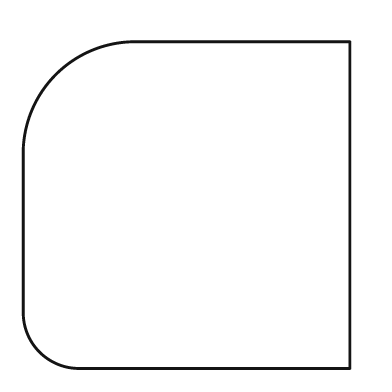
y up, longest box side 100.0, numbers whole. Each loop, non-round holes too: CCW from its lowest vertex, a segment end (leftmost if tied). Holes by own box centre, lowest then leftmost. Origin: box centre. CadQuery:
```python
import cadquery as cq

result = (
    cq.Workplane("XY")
    .moveTo(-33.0, -50.0)
    .lineTo(50.0, -50.0)
    .lineTo(50.0, 50.0)
    .lineTo(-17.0, 50.0)
    .threePointArc((-40.0, 40.0), (-50.0, 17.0))
    .lineTo(-50.0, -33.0)
    .threePointArc((-45.0, -45.0), (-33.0, -50.0))
    .close()
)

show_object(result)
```